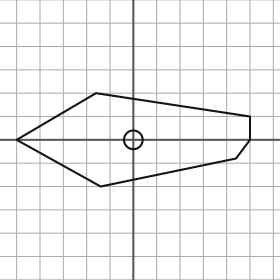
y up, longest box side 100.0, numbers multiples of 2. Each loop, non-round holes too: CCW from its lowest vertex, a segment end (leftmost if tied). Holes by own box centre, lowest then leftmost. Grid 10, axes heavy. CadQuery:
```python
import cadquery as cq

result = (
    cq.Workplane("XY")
    .moveTo(-14.0, -20.0)
    .lineTo(44.0, -8.0)
    .lineTo(50.0, 0.0)
    .lineTo(50.0, 10.0)
    .lineTo(-16.0, 20.0)
    .lineTo(-50.0, 0.0)
    .close()
    .moveTo(0.0, 0.0)
    .circle(4.0)
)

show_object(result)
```